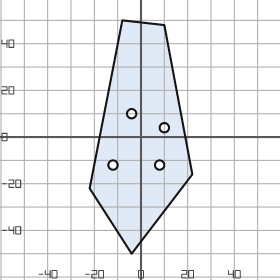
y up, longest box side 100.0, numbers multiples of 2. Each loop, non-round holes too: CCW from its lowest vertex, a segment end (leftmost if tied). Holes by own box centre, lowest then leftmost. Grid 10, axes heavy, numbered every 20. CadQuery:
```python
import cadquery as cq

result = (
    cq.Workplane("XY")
    .moveTo(-4.0, -50.0)
    .lineTo(22.0, -16.0)
    .lineTo(10.0, 48.0)
    .lineTo(-8.0, 50.0)
    .lineTo(-22.0, -22.0)
    .close()
    .moveTo(-12.0, -12.0)
    .circle(2.0)
    .moveTo(8.0, -12.0)
    .circle(2.0)
    .moveTo(10.0, 4.0)
    .circle(2.0)
    .moveTo(-4.0, 10.0)
    .circle(2.0)
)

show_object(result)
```